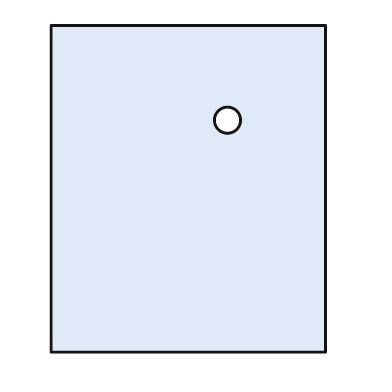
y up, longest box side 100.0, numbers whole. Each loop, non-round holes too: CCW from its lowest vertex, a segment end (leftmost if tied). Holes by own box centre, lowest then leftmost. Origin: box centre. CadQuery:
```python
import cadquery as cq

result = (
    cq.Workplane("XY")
    .moveTo(-42.0, -50.0)
    .lineTo(42.0, -50.0)
    .lineTo(42.0, 50.0)
    .lineTo(-42.0, 50.0)
    .close()
    .moveTo(12.0, 21.0)
    .circle(4.0)
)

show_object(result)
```